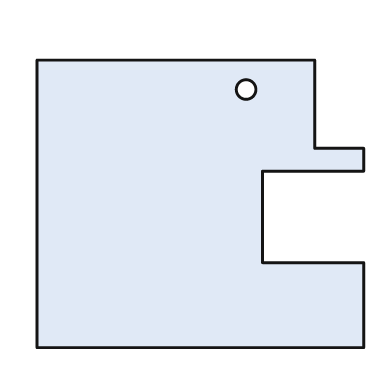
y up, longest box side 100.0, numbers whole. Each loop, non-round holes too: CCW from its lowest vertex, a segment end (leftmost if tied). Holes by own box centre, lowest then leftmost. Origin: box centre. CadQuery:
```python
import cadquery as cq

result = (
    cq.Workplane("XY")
    .moveTo(-50.0, -44.0)
    .lineTo(50.0, -44.0)
    .lineTo(50.0, -18.0)
    .lineTo(19.0, -18.0)
    .lineTo(19.0, 10.0)
    .lineTo(50.0, 10.0)
    .lineTo(50.0, 17.0)
    .lineTo(35.0, 17.0)
    .lineTo(35.0, 44.0)
    .lineTo(-50.0, 44.0)
    .close()
    .moveTo(14.0, 35.0)
    .circle(3.0)
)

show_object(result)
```